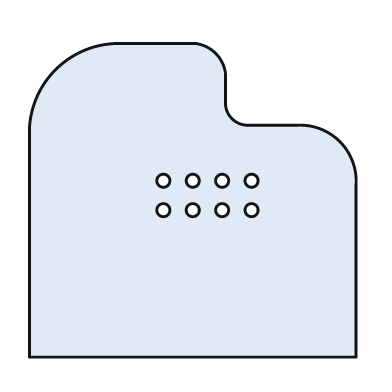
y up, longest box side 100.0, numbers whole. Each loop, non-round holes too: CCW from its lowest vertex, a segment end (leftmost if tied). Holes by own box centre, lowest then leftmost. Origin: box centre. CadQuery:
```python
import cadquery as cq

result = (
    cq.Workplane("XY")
    .moveTo(-50.0, -48.0)
    .lineTo(50.0, -48.0)
    .lineTo(50.0, 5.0)
    .threePointArc((45.0, 18.0), (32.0, 23.0))
    .lineTo(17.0, 23.0)
    .threePointArc((12.0, 25.0), (10.0, 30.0))
    .lineTo(10.0, 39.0)
    .threePointArc((7.0, 45.0), (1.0, 48.0))
    .lineTo(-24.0, 48.0)
    .threePointArc((-42.0, 40.0), (-50.0, 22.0))
    .close()
    .moveTo(-9.0, -3.0)
    .circle(2.0)
    .moveTo(0.0, -3.0)
    .circle(2.0)
    .moveTo(9.0, -3.0)
    .circle(2.0)
    .moveTo(18.0, -3.0)
    .circle(2.0)
    .moveTo(-9.0, 6.0)
    .circle(2.0)
    .moveTo(0.0, 6.0)
    .circle(2.0)
    .moveTo(9.0, 6.0)
    .circle(2.0)
    .moveTo(18.0, 6.0)
    .circle(2.0)
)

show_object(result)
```